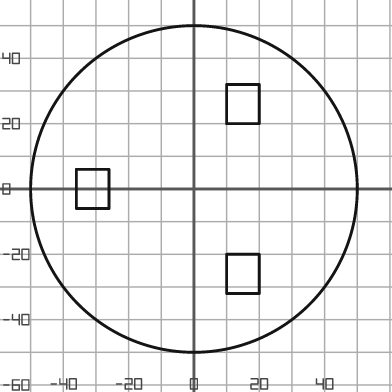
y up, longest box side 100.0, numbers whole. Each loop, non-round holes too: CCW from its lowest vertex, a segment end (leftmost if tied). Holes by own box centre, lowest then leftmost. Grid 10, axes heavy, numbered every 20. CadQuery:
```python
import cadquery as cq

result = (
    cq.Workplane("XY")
    .moveTo(0.0, 0.0)
    .circle(50.0)
    .moveTo(10.0, -32.0)
    .lineTo(20.0, -32.0)
    .lineTo(20.0, -20.0)
    .lineTo(10.0, -20.0)
    .close()
    .moveTo(-36.0, -6.0)
    .lineTo(-26.0, -6.0)
    .lineTo(-26.0, 6.0)
    .lineTo(-36.0, 6.0)
    .close()
    .moveTo(10.0, 20.0)
    .lineTo(20.0, 20.0)
    .lineTo(20.0, 32.0)
    .lineTo(10.0, 32.0)
    .close()
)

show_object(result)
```